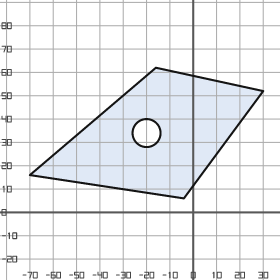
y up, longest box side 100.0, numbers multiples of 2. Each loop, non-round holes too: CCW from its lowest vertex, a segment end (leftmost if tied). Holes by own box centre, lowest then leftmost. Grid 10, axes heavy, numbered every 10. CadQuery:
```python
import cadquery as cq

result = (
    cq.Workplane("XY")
    .moveTo(-4.0, 6.0)
    .lineTo(30.0, 52.0)
    .lineTo(-16.0, 62.0)
    .lineTo(-70.0, 16.0)
    .close()
    .moveTo(-20.0, 34.0)
    .circle(6.0)
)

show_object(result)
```